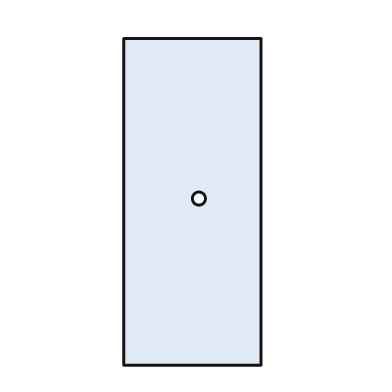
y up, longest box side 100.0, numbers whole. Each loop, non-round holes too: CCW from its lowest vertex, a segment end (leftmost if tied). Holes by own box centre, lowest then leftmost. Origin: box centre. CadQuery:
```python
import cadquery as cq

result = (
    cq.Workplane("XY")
    .moveTo(-21.0, -50.0)
    .lineTo(21.0, -50.0)
    .lineTo(21.0, 50.0)
    .lineTo(-21.0, 50.0)
    .close()
    .moveTo(2.0, 1.0)
    .circle(2.0)
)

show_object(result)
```